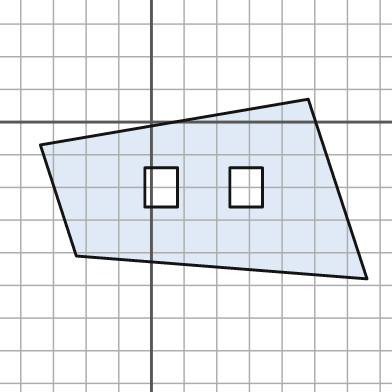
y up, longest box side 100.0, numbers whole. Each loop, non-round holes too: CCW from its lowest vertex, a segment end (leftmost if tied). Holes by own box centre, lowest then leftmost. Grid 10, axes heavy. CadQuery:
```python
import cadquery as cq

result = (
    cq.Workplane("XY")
    .moveTo(66.0, -48.0)
    .lineTo(48.0, 7.0)
    .lineTo(-34.0, -7.0)
    .lineTo(-23.0, -41.0)
    .close()
    .moveTo(-2.0, -26.0)
    .lineTo(8.0, -26.0)
    .lineTo(8.0, -14.0)
    .lineTo(-2.0, -14.0)
    .close()
    .moveTo(24.0, -26.0)
    .lineTo(34.0, -26.0)
    .lineTo(34.0, -14.0)
    .lineTo(24.0, -14.0)
    .close()
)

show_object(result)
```